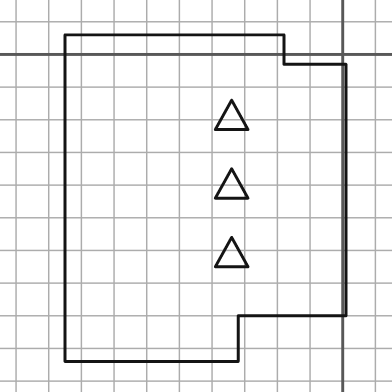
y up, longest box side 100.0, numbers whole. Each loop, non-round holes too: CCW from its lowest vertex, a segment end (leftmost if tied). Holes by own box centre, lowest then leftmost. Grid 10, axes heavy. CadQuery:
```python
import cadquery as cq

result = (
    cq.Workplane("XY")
    .moveTo(-85.0, -94.0)
    .lineTo(-32.0, -94.0)
    .lineTo(-32.0, -80.0)
    .lineTo(1.0, -80.0)
    .lineTo(1.0, -3.0)
    .lineTo(-18.0, -3.0)
    .lineTo(-18.0, 6.0)
    .lineTo(-85.0, 6.0)
    .close()
    .moveTo(-39.0, -65.0)
    .lineTo(-29.0, -65.0)
    .lineTo(-34.0, -56.0)
    .close()
    .moveTo(-39.0, -44.0)
    .lineTo(-29.0, -44.0)
    .lineTo(-34.0, -35.0)
    .close()
    .moveTo(-39.0, -23.0)
    .lineTo(-29.0, -23.0)
    .lineTo(-34.0, -14.0)
    .close()
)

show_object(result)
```